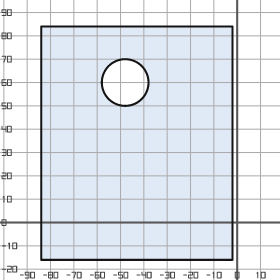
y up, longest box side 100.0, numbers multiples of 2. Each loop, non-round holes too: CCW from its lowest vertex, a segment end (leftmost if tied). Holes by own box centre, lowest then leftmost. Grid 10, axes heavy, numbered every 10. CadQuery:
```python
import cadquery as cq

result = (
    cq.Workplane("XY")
    .moveTo(-84.0, -16.0)
    .lineTo(-2.0, -16.0)
    .lineTo(-2.0, 84.0)
    .lineTo(-84.0, 84.0)
    .close()
    .moveTo(-48.0, 60.0)
    .circle(10.0)
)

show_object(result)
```